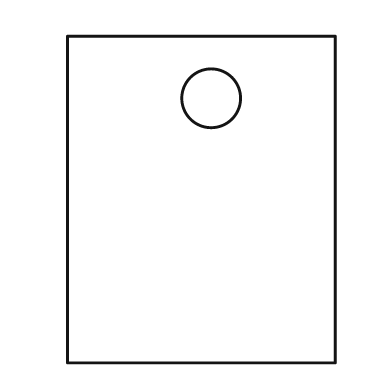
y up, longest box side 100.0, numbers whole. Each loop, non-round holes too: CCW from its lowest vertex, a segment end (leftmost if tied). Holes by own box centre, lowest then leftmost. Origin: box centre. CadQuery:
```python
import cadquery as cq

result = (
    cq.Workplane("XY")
    .moveTo(-41.0, -50.0)
    .lineTo(41.0, -50.0)
    .lineTo(41.0, 50.0)
    .lineTo(-41.0, 50.0)
    .close()
    .moveTo(3.0, 31.0)
    .circle(9.0)
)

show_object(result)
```